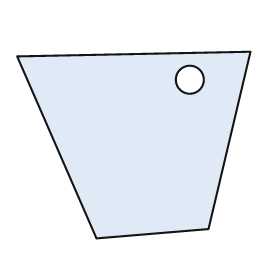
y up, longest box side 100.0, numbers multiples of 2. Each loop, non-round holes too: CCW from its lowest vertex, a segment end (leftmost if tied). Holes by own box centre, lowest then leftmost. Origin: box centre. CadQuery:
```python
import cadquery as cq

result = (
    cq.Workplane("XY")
    .moveTo(-16.0, -40.0)
    .lineTo(32.0, -36.0)
    .lineTo(50.0, 40.0)
    .lineTo(-50.0, 38.0)
    .close()
    .moveTo(24.0, 28.0)
    .circle(6.0)
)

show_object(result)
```